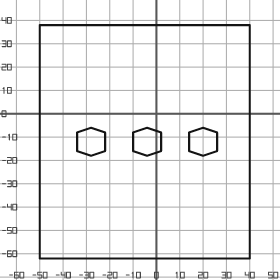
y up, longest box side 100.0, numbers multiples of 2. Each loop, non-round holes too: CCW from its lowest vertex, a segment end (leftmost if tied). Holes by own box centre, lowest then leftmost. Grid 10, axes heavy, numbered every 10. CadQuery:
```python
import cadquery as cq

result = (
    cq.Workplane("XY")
    .moveTo(-50.0, -62.0)
    .lineTo(40.0, -62.0)
    .lineTo(40.0, 38.0)
    .lineTo(-50.0, 38.0)
    .close()
    .moveTo(-28.0, -18.0)
    .lineTo(-22.0, -16.0)
    .lineTo(-22.0, -8.0)
    .lineTo(-28.0, -6.0)
    .lineTo(-34.0, -8.0)
    .lineTo(-34.0, -16.0)
    .close()
    .moveTo(-4.0, -18.0)
    .lineTo(2.0, -16.0)
    .lineTo(2.0, -8.0)
    .lineTo(-4.0, -6.0)
    .lineTo(-10.0, -8.0)
    .lineTo(-10.0, -16.0)
    .close()
    .moveTo(20.0, -18.0)
    .lineTo(26.0, -16.0)
    .lineTo(26.0, -8.0)
    .lineTo(20.0, -6.0)
    .lineTo(14.0, -8.0)
    .lineTo(14.0, -16.0)
    .close()
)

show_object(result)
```